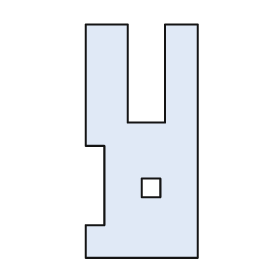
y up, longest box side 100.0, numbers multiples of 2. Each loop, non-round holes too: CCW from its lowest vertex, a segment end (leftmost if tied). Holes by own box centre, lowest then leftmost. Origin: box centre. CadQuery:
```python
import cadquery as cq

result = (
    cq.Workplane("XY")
    .moveTo(-24.0, -50.0)
    .lineTo(24.0, -50.0)
    .lineTo(24.0, 50.0)
    .lineTo(10.0, 50.0)
    .lineTo(10.0, 8.0)
    .lineTo(-6.0, 8.0)
    .lineTo(-6.0, 50.0)
    .lineTo(-24.0, 50.0)
    .lineTo(-24.0, -2.0)
    .lineTo(-16.0, -2.0)
    .lineTo(-16.0, -36.0)
    .lineTo(-24.0, -36.0)
    .close()
    .moveTo(0.0, -24.0)
    .lineTo(8.0, -24.0)
    .lineTo(8.0, -16.0)
    .lineTo(0.0, -16.0)
    .close()
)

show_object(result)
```